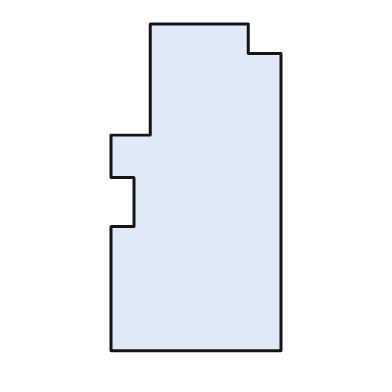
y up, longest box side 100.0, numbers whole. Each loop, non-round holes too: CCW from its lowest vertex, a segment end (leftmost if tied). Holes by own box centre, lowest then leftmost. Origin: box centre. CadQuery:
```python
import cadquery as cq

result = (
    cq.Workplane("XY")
    .moveTo(-26.0, -50.0)
    .lineTo(26.0, -50.0)
    .lineTo(26.0, 41.0)
    .lineTo(16.0, 41.0)
    .lineTo(16.0, 50.0)
    .lineTo(-14.0, 50.0)
    .lineTo(-14.0, 16.0)
    .lineTo(-26.0, 16.0)
    .lineTo(-26.0, 3.0)
    .lineTo(-19.0, 3.0)
    .lineTo(-19.0, -12.0)
    .lineTo(-26.0, -12.0)
    .close()
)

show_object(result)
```